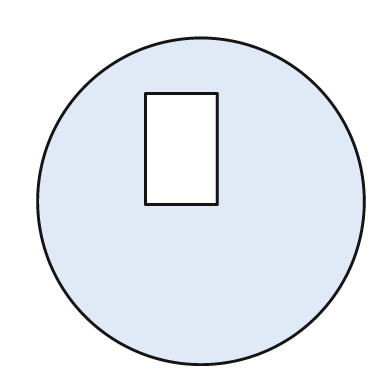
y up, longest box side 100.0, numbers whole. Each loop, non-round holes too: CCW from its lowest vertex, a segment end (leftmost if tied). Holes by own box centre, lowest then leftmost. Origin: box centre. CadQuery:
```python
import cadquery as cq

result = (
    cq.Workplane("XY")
    .moveTo(0.0, 0.0)
    .circle(50.0)
    .moveTo(-17.0, -1.0)
    .lineTo(5.0, -1.0)
    .lineTo(5.0, 33.0)
    .lineTo(-17.0, 33.0)
    .close()
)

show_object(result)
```